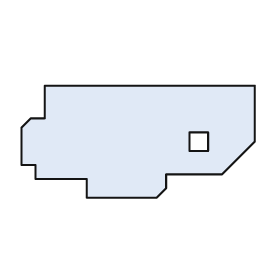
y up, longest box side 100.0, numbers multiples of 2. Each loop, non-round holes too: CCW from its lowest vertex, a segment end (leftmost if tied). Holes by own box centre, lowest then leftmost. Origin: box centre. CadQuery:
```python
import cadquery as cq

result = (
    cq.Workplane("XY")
    .moveTo(-22.0, -24.0)
    .lineTo(8.0, -24.0)
    .lineTo(12.0, -20.0)
    .lineTo(12.0, -14.0)
    .lineTo(36.0, -14.0)
    .lineTo(50.0, 0.0)
    .lineTo(50.0, 24.0)
    .lineTo(-40.0, 24.0)
    .lineTo(-40.0, 10.0)
    .lineTo(-46.0, 10.0)
    .lineTo(-50.0, 6.0)
    .lineTo(-50.0, -10.0)
    .lineTo(-44.0, -10.0)
    .lineTo(-44.0, -16.0)
    .lineTo(-22.0, -16.0)
    .close()
    .moveTo(22.0, -4.0)
    .lineTo(30.0, -4.0)
    .lineTo(30.0, 4.0)
    .lineTo(22.0, 4.0)
    .close()
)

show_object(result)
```